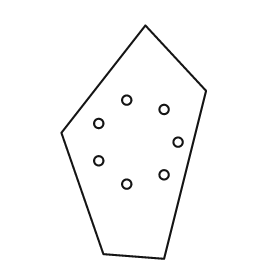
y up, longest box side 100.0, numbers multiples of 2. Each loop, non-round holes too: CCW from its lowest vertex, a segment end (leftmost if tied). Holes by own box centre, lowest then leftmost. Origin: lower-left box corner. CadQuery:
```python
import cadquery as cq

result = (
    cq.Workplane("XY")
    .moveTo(44.0, 0.0)
    .lineTo(62.0, 72.0)
    .lineTo(36.0, 100.0)
    .lineTo(0.0, 54.0)
    .lineTo(18.0, 2.0)
    .close()
    .moveTo(28.0, 32.0)
    .circle(2.0)
    .moveTo(44.0, 36.0)
    .circle(2.0)
    .moveTo(16.0, 42.0)
    .circle(2.0)
    .moveTo(50.0, 50.0)
    .circle(2.0)
    .moveTo(16.0, 58.0)
    .circle(2.0)
    .moveTo(44.0, 64.0)
    .circle(2.0)
    .moveTo(28.0, 68.0)
    .circle(2.0)
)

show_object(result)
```